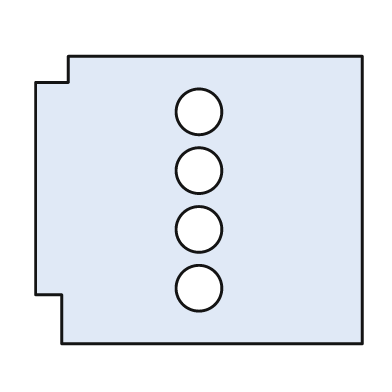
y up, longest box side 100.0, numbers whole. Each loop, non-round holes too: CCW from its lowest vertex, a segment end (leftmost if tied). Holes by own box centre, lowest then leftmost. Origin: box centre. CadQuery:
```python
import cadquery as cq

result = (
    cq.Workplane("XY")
    .moveTo(-42.0, -44.0)
    .lineTo(50.0, -44.0)
    .lineTo(50.0, 44.0)
    .lineTo(-40.0, 44.0)
    .lineTo(-40.0, 36.0)
    .lineTo(-50.0, 36.0)
    .lineTo(-50.0, -29.0)
    .lineTo(-42.0, -29.0)
    .close()
    .moveTo(0.0, -27.0)
    .circle(7.0)
    .moveTo(0.0, -9.0)
    .circle(7.0)
    .moveTo(0.0, 9.0)
    .circle(7.0)
    .moveTo(0.0, 27.0)
    .circle(7.0)
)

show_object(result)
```